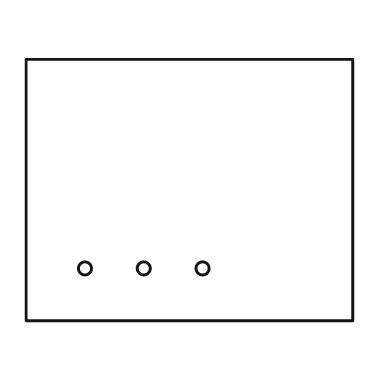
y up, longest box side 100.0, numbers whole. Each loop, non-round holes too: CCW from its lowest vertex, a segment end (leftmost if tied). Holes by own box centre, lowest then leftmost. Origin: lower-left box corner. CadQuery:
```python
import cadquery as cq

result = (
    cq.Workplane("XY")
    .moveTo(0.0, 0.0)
    .lineTo(100.0, 0.0)
    .lineTo(100.0, 80.0)
    .lineTo(0.0, 80.0)
    .close()
    .moveTo(18.0, 16.0)
    .circle(2.0)
    .moveTo(36.0, 16.0)
    .circle(2.0)
    .moveTo(54.0, 16.0)
    .circle(2.0)
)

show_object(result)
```